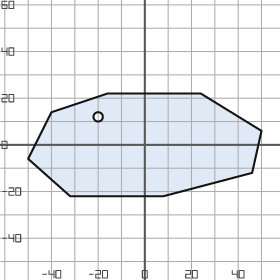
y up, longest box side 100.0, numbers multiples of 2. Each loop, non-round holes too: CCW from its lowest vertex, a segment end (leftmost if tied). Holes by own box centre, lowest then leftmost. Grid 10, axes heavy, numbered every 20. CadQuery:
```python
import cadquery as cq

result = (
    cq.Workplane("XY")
    .moveTo(-32.0, -22.0)
    .lineTo(8.0, -22.0)
    .lineTo(46.0, -12.0)
    .lineTo(50.0, 6.0)
    .lineTo(24.0, 22.0)
    .lineTo(-16.0, 22.0)
    .lineTo(-40.0, 14.0)
    .lineTo(-50.0, -6.0)
    .close()
    .moveTo(-20.0, 12.0)
    .circle(2.0)
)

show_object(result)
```